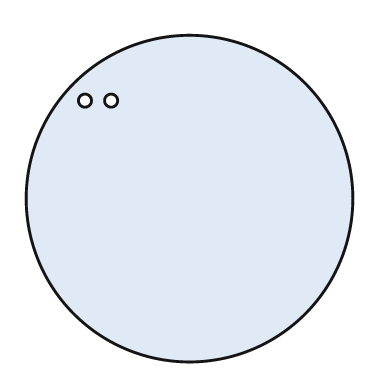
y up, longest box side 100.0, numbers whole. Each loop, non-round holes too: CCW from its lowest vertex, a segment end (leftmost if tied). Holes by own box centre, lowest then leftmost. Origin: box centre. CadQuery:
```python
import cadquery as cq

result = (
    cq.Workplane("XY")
    .moveTo(0.0, 0.0)
    .circle(50.0)
    .moveTo(-32.0, 30.0)
    .circle(2.0)
    .moveTo(-24.0, 30.0)
    .circle(2.0)
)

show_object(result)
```